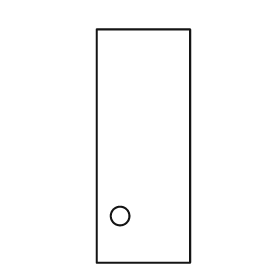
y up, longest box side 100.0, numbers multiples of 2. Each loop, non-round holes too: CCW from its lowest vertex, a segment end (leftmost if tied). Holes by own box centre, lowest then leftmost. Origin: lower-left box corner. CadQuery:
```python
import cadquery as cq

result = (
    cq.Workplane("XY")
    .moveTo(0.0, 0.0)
    .lineTo(40.0, 0.0)
    .lineTo(40.0, 100.0)
    .lineTo(0.0, 100.0)
    .close()
    .moveTo(10.0, 20.0)
    .circle(4.0)
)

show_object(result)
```